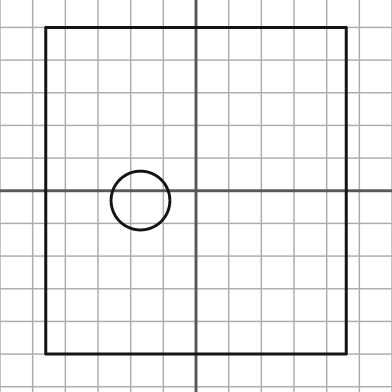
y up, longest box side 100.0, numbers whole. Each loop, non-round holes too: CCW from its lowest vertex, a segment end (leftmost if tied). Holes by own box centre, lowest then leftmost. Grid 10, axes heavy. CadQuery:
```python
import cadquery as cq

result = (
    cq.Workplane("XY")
    .moveTo(-46.0, -50.0)
    .lineTo(46.0, -50.0)
    .lineTo(46.0, 50.0)
    .lineTo(-46.0, 50.0)
    .close()
    .moveTo(-17.0, -3.0)
    .circle(9.0)
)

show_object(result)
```